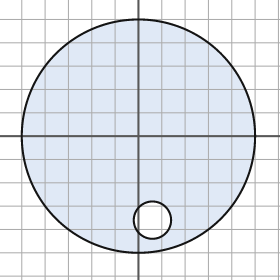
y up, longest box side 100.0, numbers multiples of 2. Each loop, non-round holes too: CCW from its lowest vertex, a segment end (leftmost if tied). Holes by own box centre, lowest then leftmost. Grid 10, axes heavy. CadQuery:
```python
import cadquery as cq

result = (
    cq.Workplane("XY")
    .moveTo(0.0, 0.0)
    .circle(50.0)
    .moveTo(6.0, -36.0)
    .circle(8.0)
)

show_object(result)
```